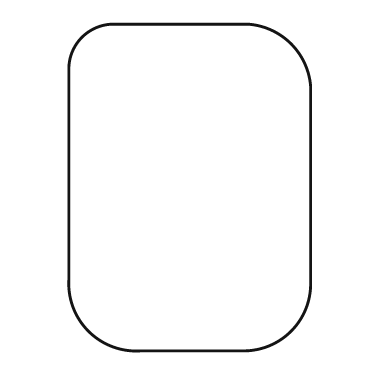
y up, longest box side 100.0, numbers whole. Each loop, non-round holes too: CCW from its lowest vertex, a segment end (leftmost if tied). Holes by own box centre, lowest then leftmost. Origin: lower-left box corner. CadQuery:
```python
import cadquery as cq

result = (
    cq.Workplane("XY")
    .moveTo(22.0, 0.0)
    .lineTo(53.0, 0.0)
    .threePointArc((68.0, 6.0), (74.0, 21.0))
    .lineTo(74.0, 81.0)
    .threePointArc((68.0, 94.0), (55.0, 100.0))
    .lineTo(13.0, 100.0)
    .threePointArc((4.0, 96.0), (0.0, 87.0))
    .lineTo(0.0, 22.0)
    .threePointArc((6.0, 6.0), (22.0, 0.0))
    .close()
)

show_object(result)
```